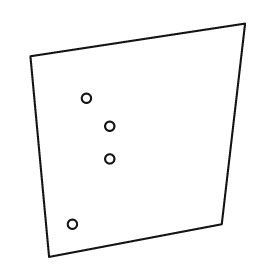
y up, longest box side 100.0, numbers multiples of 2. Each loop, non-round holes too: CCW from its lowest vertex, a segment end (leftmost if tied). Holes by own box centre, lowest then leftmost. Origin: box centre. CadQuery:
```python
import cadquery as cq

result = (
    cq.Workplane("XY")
    .moveTo(-38.0, -50.0)
    .lineTo(36.0, -36.0)
    .lineTo(46.0, 50.0)
    .lineTo(-46.0, 36.0)
    .close()
    .moveTo(-28.0, -36.0)
    .circle(2.0)
    .moveTo(-12.0, -8.0)
    .circle(2.0)
    .moveTo(-12.0, 6.0)
    .circle(2.0)
    .moveTo(-22.0, 18.0)
    .circle(2.0)
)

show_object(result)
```